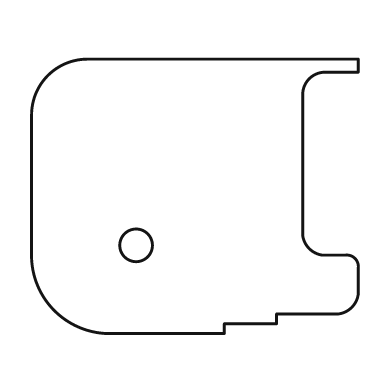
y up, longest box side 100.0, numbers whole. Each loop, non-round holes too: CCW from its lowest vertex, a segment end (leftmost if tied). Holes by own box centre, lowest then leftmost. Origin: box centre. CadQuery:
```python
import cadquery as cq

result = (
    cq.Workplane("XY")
    .moveTo(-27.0, -42.0)
    .lineTo(9.0, -42.0)
    .lineTo(9.0, -39.0)
    .lineTo(25.0, -39.0)
    .lineTo(25.0, -36.0)
    .lineTo(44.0, -36.0)
    .threePointArc((48.0, -34.0), (50.0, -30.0))
    .lineTo(50.0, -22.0)
    .threePointArc((49.0, -19.0), (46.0, -18.0))
    .lineTo(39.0, -18.0)
    .threePointArc((35.0, -16.0), (33.0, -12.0))
    .lineTo(33.0, 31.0)
    .threePointArc((35.0, 36.0), (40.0, 38.0))
    .lineTo(50.0, 38.0)
    .lineTo(50.0, 42.0)
    .lineTo(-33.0, 42.0)
    .threePointArc((-45.0, 37.0), (-50.0, 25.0))
    .lineTo(-50.0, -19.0)
    .threePointArc((-43.0, -35.0), (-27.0, -42.0))
    .close()
    .moveTo(-18.0, -15.0)
    .circle(5.0)
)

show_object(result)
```